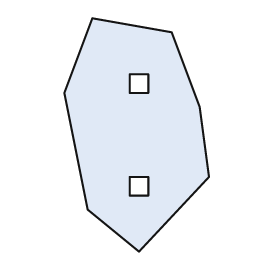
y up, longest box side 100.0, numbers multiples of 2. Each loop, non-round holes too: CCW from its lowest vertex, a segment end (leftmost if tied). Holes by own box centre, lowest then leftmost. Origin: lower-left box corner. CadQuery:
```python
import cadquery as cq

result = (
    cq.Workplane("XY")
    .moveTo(32.0, 0.0)
    .lineTo(62.0, 32.0)
    .lineTo(58.0, 62.0)
    .lineTo(46.0, 94.0)
    .lineTo(12.0, 100.0)
    .lineTo(0.0, 68.0)
    .lineTo(10.0, 18.0)
    .close()
    .moveTo(28.0, 24.0)
    .lineTo(36.0, 24.0)
    .lineTo(36.0, 32.0)
    .lineTo(28.0, 32.0)
    .close()
    .moveTo(28.0, 68.0)
    .lineTo(36.0, 68.0)
    .lineTo(36.0, 76.0)
    .lineTo(28.0, 76.0)
    .close()
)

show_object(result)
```